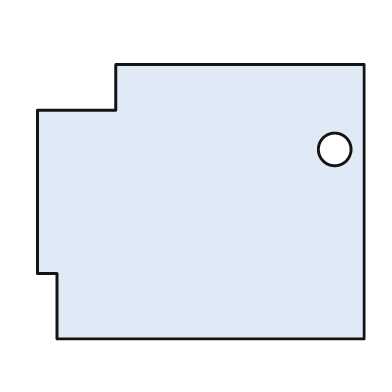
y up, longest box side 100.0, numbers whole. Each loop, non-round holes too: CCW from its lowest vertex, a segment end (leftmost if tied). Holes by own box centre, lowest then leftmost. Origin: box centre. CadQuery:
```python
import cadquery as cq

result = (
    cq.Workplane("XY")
    .moveTo(-44.0, -42.0)
    .lineTo(50.0, -42.0)
    .lineTo(50.0, 42.0)
    .lineTo(-26.0, 42.0)
    .lineTo(-26.0, 28.0)
    .lineTo(-50.0, 28.0)
    .lineTo(-50.0, -22.0)
    .lineTo(-44.0, -22.0)
    .close()
    .moveTo(41.0, 16.0)
    .circle(5.0)
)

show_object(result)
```